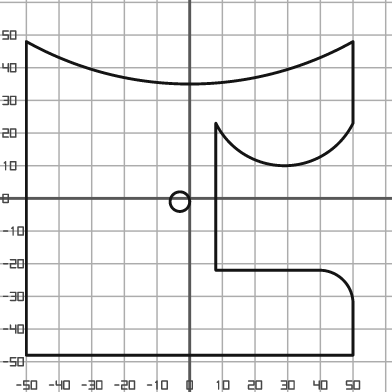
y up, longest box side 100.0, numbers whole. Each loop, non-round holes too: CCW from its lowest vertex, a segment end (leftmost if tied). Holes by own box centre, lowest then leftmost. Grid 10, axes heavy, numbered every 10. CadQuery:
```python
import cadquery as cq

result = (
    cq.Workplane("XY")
    .moveTo(-50.0, -48.0)
    .lineTo(50.0, -48.0)
    .lineTo(50.0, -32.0)
    .threePointArc((47.0, -25.0), (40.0, -22.0))
    .lineTo(8.0, -22.0)
    .lineTo(8.0, 23.0)
    .threePointArc((29.0, 10.0), (50.0, 23.0))
    .lineTo(50.0, 48.0)
    .threePointArc((0.0, 35.0), (-50.0, 48.0))
    .close()
    .moveTo(-3.0, -1.0)
    .circle(3.0)
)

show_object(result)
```